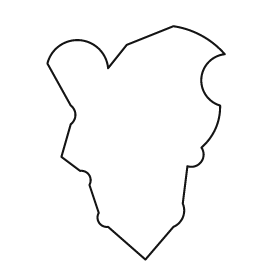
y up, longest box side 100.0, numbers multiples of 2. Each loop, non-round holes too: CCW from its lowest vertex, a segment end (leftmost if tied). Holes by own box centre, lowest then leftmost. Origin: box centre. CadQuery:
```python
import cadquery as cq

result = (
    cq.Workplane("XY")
    .moveTo(4.0, -50.0)
    .lineTo(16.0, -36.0)
    .threePointArc((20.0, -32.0), (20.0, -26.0))
    .lineTo(22.0, -10.0)
    .threePointArc((28.0, -8.0), (28.0, -2.0))
    .threePointArc((34.0, 6.0), (36.0, 16.0))
    .threePointArc((28.0, 28.0), (38.0, 38.0))
    .threePointArc((28.0, 46.0), (16.0, 50.0))
    .lineTo(-4.0, 42.0)
    .lineTo(-12.0, 32.0)
    .threePointArc((-24.0, 44.0), (-38.0, 34.0))
    .lineTo(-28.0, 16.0)
    .threePointArc((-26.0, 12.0), (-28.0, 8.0))
    .lineTo(-32.0, -6.0)
    .lineTo(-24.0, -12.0)
    .threePointArc((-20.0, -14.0), (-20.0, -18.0))
    .lineTo(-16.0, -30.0)
    .threePointArc((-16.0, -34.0), (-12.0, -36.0))
    .close()
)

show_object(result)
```